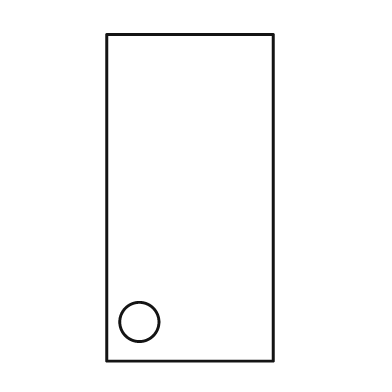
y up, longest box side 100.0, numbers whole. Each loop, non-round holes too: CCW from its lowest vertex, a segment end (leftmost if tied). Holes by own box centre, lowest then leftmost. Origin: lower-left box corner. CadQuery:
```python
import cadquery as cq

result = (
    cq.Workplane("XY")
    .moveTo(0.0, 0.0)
    .lineTo(51.0, 0.0)
    .lineTo(51.0, 100.0)
    .lineTo(0.0, 100.0)
    .close()
    .moveTo(10.0, 12.0)
    .circle(6.0)
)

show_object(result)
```